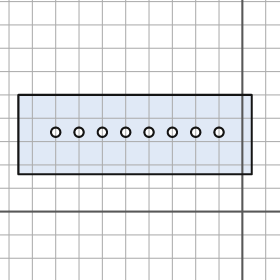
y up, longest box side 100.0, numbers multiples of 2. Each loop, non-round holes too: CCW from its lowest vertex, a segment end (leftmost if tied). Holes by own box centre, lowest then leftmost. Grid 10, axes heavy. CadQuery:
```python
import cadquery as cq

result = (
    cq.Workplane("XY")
    .moveTo(-96.0, 16.0)
    .lineTo(4.0, 16.0)
    .lineTo(4.0, 50.0)
    .lineTo(-96.0, 50.0)
    .close()
    .moveTo(-80.0, 34.0)
    .circle(2.0)
    .moveTo(-70.0, 34.0)
    .circle(2.0)
    .moveTo(-60.0, 34.0)
    .circle(2.0)
    .moveTo(-50.0, 34.0)
    .circle(2.0)
    .moveTo(-40.0, 34.0)
    .circle(2.0)
    .moveTo(-30.0, 34.0)
    .circle(2.0)
    .moveTo(-20.0, 34.0)
    .circle(2.0)
    .moveTo(-10.0, 34.0)
    .circle(2.0)
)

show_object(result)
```